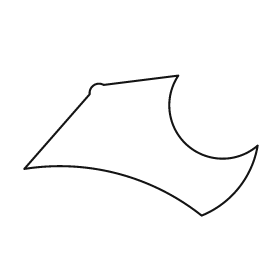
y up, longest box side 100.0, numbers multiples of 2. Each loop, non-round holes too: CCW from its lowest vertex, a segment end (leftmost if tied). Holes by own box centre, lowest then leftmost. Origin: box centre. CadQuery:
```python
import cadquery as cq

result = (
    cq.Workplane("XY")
    .moveTo(26.0, -30.0)
    .threePointArc((42.0, -18.0), (50.0, 0.0))
    .threePointArc((20.0, 0.0), (16.0, 30.0))
    .lineTo(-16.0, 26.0)
    .threePointArc((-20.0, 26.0), (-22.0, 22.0))
    .lineTo(-50.0, -10.0)
    .threePointArc((-10.0, -12.0), (26.0, -30.0))
    .close()
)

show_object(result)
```